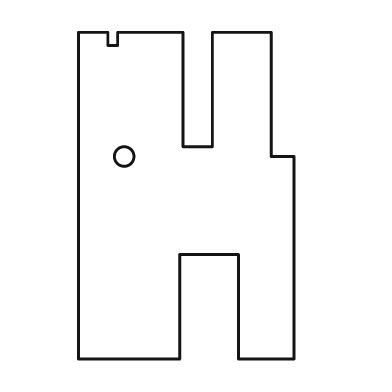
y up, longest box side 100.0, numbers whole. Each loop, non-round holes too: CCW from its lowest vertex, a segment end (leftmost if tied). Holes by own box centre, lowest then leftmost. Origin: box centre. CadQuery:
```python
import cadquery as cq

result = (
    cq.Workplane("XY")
    .moveTo(-33.0, -50.0)
    .lineTo(-2.0, -50.0)
    .lineTo(-2.0, -18.0)
    .lineTo(16.0, -18.0)
    .lineTo(16.0, -50.0)
    .lineTo(33.0, -50.0)
    .lineTo(33.0, 12.0)
    .lineTo(26.0, 12.0)
    .lineTo(26.0, 50.0)
    .lineTo(8.0, 50.0)
    .lineTo(8.0, 15.0)
    .lineTo(-1.0, 15.0)
    .lineTo(-1.0, 50.0)
    .lineTo(-21.0, 50.0)
    .lineTo(-21.0, 46.0)
    .lineTo(-24.0, 46.0)
    .lineTo(-24.0, 50.0)
    .lineTo(-33.0, 50.0)
    .close()
    .moveTo(-19.0, 12.0)
    .circle(3.0)
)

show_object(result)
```